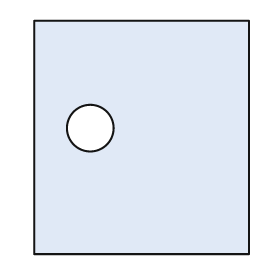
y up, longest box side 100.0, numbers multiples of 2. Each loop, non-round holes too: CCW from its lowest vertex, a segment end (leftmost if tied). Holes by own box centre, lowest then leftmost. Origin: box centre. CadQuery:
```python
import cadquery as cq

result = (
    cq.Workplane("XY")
    .moveTo(-46.0, -50.0)
    .lineTo(46.0, -50.0)
    .lineTo(46.0, 50.0)
    .lineTo(-46.0, 50.0)
    .close()
    .moveTo(-22.0, 4.0)
    .circle(10.0)
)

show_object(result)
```